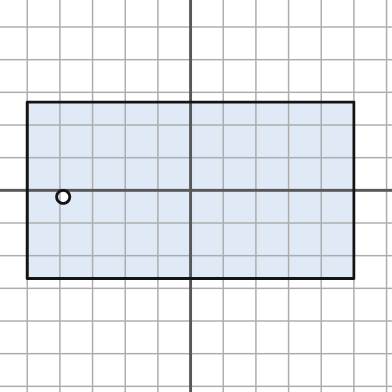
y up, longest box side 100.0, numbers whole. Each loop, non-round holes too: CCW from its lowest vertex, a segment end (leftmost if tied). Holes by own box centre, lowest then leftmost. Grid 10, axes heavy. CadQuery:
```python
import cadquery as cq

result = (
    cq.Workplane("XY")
    .moveTo(-50.0, -27.0)
    .lineTo(50.0, -27.0)
    .lineTo(50.0, 27.0)
    .lineTo(-50.0, 27.0)
    .close()
    .moveTo(-39.0, -2.0)
    .circle(2.0)
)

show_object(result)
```